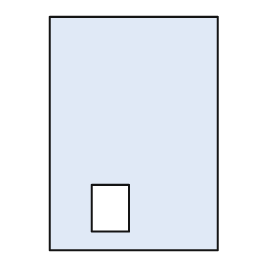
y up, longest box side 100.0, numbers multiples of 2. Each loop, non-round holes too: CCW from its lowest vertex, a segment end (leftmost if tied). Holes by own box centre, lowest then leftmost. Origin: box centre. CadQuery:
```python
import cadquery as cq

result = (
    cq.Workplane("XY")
    .moveTo(-36.0, -50.0)
    .lineTo(36.0, -50.0)
    .lineTo(36.0, 50.0)
    .lineTo(-36.0, 50.0)
    .close()
    .moveTo(-18.0, -42.0)
    .lineTo(-2.0, -42.0)
    .lineTo(-2.0, -22.0)
    .lineTo(-18.0, -22.0)
    .close()
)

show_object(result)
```